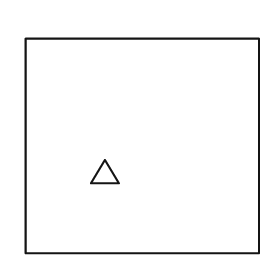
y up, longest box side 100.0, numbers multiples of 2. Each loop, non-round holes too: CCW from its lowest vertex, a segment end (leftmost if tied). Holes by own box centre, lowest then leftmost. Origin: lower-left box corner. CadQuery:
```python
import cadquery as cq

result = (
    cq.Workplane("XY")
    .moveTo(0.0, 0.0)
    .lineTo(100.0, 0.0)
    .lineTo(100.0, 92.0)
    .lineTo(0.0, 92.0)
    .close()
    .moveTo(28.0, 30.0)
    .lineTo(40.0, 30.0)
    .lineTo(34.0, 40.0)
    .close()
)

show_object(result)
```